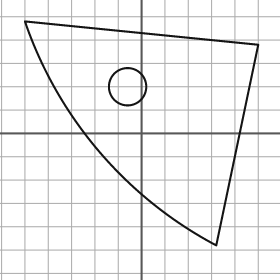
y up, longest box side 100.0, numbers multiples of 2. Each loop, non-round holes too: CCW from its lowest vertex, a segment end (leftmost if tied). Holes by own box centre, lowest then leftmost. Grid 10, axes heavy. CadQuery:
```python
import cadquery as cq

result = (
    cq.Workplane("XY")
    .moveTo(32.0, -48.0)
    .lineTo(50.0, 38.0)
    .lineTo(-50.0, 48.0)
    .threePointArc((-18.0, -8.0), (32.0, -48.0))
    .close()
    .moveTo(-6.0, 20.0)
    .circle(8.0)
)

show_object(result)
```